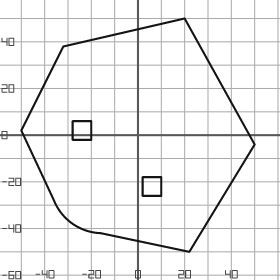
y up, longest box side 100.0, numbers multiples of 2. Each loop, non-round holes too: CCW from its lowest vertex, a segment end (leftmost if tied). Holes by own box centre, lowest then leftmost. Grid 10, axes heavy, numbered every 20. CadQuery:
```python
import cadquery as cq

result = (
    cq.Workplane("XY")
    .moveTo(22.0, -50.0)
    .lineTo(50.0, -4.0)
    .lineTo(20.0, 50.0)
    .lineTo(-32.0, 38.0)
    .lineTo(-50.0, 2.0)
    .lineTo(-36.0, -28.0)
    .threePointArc((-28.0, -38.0), (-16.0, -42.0))
    .close()
    .moveTo(2.0, -26.0)
    .lineTo(10.0, -26.0)
    .lineTo(10.0, -18.0)
    .lineTo(2.0, -18.0)
    .close()
    .moveTo(-28.0, -2.0)
    .lineTo(-20.0, -2.0)
    .lineTo(-20.0, 6.0)
    .lineTo(-28.0, 6.0)
    .close()
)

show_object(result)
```